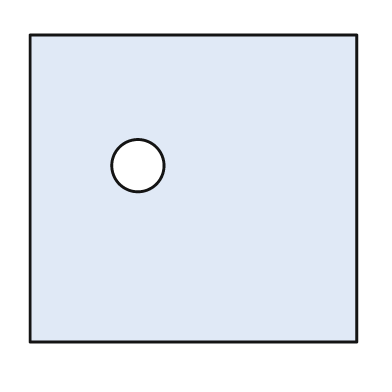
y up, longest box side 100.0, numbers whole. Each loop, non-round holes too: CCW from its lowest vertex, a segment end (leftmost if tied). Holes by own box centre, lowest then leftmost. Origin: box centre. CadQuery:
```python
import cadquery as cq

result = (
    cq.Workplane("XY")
    .moveTo(-50.0, -47.0)
    .lineTo(50.0, -47.0)
    .lineTo(50.0, 47.0)
    .lineTo(-50.0, 47.0)
    .close()
    .moveTo(-17.0, 7.0)
    .circle(8.0)
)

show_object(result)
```